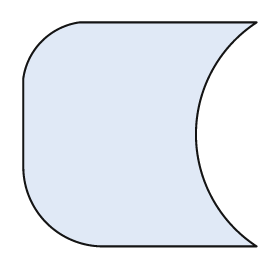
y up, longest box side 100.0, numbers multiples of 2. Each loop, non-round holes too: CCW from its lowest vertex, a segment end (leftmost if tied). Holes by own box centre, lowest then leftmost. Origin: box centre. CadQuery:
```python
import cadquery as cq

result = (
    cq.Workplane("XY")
    .moveTo(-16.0, -48.0)
    .lineTo(50.0, -48.0)
    .threePointArc((24.0, 0.0), (50.0, 48.0))
    .lineTo(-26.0, 48.0)
    .threePointArc((-42.0, 40.0), (-50.0, 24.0))
    .lineTo(-50.0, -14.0)
    .threePointArc((-40.0, -38.0), (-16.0, -48.0))
    .close()
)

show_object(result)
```